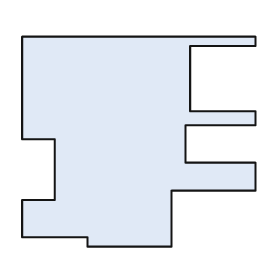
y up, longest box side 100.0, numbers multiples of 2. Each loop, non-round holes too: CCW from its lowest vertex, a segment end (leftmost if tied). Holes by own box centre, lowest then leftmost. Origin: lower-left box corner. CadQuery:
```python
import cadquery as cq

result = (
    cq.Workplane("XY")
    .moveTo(28.0, 0.0)
    .lineTo(64.0, 0.0)
    .lineTo(64.0, 24.0)
    .lineTo(100.0, 24.0)
    .lineTo(100.0, 36.0)
    .lineTo(70.0, 36.0)
    .lineTo(70.0, 52.0)
    .lineTo(100.0, 52.0)
    .lineTo(100.0, 58.0)
    .lineTo(72.0, 58.0)
    .lineTo(72.0, 86.0)
    .lineTo(100.0, 86.0)
    .lineTo(100.0, 90.0)
    .lineTo(0.0, 90.0)
    .lineTo(0.0, 46.0)
    .lineTo(14.0, 46.0)
    .lineTo(14.0, 20.0)
    .lineTo(0.0, 20.0)
    .lineTo(0.0, 4.0)
    .lineTo(28.0, 4.0)
    .close()
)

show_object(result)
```